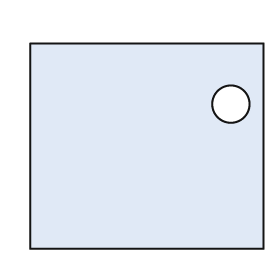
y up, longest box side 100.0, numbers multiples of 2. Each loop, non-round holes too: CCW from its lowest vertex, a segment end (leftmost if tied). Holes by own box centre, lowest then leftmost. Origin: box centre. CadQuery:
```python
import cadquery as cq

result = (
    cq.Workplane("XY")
    .moveTo(-50.0, -44.0)
    .lineTo(50.0, -44.0)
    .lineTo(50.0, 44.0)
    .lineTo(-50.0, 44.0)
    .close()
    .moveTo(36.0, 18.0)
    .circle(8.0)
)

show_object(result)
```